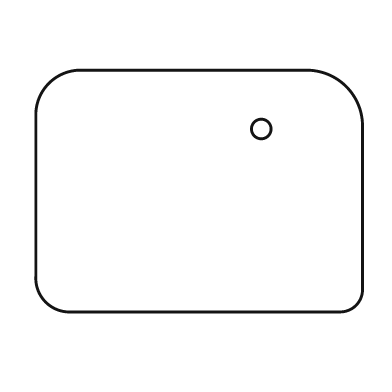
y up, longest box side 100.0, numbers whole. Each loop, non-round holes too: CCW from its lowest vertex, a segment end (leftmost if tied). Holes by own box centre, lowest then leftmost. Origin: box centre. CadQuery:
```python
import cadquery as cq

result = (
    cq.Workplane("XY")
    .moveTo(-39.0, -37.0)
    .lineTo(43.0, -37.0)
    .threePointArc((48.0, -35.0), (50.0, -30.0))
    .lineTo(50.0, 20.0)
    .threePointArc((45.0, 32.0), (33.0, 37.0))
    .lineTo(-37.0, 37.0)
    .threePointArc((-46.0, 33.0), (-50.0, 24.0))
    .lineTo(-50.0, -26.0)
    .threePointArc((-47.0, -34.0), (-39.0, -37.0))
    .close()
    .moveTo(19.0, 19.0)
    .circle(3.0)
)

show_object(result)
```